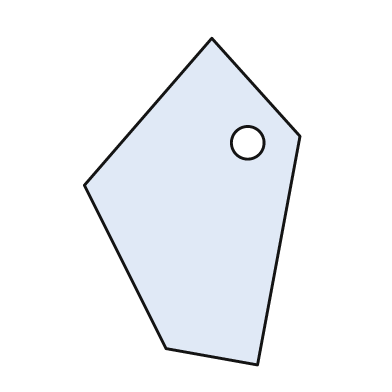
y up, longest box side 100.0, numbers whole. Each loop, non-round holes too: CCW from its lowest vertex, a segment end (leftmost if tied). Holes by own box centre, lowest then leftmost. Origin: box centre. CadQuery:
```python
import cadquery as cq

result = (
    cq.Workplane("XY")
    .moveTo(20.0, -50.0)
    .lineTo(33.0, 20.0)
    .lineTo(6.0, 50.0)
    .lineTo(-33.0, 5.0)
    .lineTo(-8.0, -45.0)
    .close()
    .moveTo(17.0, 18.0)
    .circle(5.0)
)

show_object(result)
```